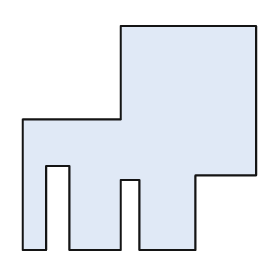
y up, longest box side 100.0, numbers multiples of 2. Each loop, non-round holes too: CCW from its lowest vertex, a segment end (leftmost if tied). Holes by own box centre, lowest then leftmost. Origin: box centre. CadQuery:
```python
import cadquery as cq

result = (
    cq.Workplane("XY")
    .moveTo(-50.0, -48.0)
    .lineTo(-40.0, -48.0)
    .lineTo(-40.0, -12.0)
    .lineTo(-30.0, -12.0)
    .lineTo(-30.0, -48.0)
    .lineTo(-8.0, -48.0)
    .lineTo(-8.0, -18.0)
    .lineTo(0.0, -18.0)
    .lineTo(0.0, -48.0)
    .lineTo(24.0, -48.0)
    .lineTo(24.0, -16.0)
    .lineTo(50.0, -16.0)
    .lineTo(50.0, 48.0)
    .lineTo(-8.0, 48.0)
    .lineTo(-8.0, 8.0)
    .lineTo(-50.0, 8.0)
    .close()
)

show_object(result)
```